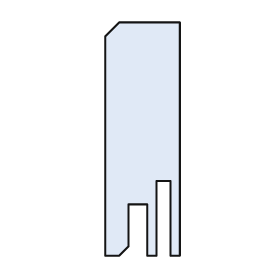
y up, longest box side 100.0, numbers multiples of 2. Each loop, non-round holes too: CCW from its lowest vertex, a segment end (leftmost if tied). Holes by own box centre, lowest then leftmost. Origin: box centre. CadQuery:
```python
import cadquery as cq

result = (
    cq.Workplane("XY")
    .moveTo(-16.0, -50.0)
    .lineTo(-10.0, -50.0)
    .lineTo(-6.0, -46.0)
    .lineTo(-6.0, -28.0)
    .lineTo(2.0, -28.0)
    .lineTo(2.0, -50.0)
    .lineTo(6.0, -50.0)
    .lineTo(6.0, -18.0)
    .lineTo(12.0, -18.0)
    .lineTo(12.0, -50.0)
    .lineTo(16.0, -50.0)
    .lineTo(16.0, 50.0)
    .lineTo(-10.0, 50.0)
    .lineTo(-16.0, 44.0)
    .close()
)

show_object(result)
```